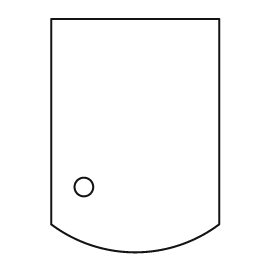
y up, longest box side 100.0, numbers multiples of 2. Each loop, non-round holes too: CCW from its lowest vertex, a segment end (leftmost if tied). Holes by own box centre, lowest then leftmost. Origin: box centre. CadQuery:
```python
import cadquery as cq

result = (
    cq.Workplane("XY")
    .moveTo(-36.0, -38.0)
    .threePointArc((0.0, -50.0), (36.0, -38.0))
    .lineTo(36.0, 50.0)
    .lineTo(-36.0, 50.0)
    .close()
    .moveTo(-22.0, -22.0)
    .circle(4.0)
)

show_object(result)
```